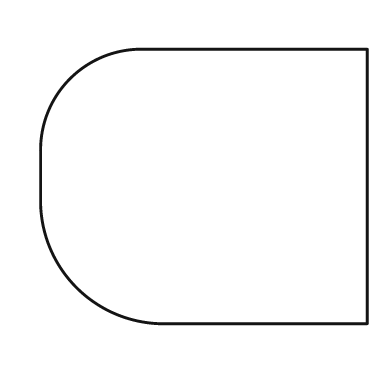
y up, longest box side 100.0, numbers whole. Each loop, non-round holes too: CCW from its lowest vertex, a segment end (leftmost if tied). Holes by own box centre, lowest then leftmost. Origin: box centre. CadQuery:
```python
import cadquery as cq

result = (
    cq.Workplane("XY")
    .moveTo(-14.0, -42.0)
    .lineTo(50.0, -42.0)
    .lineTo(50.0, 42.0)
    .lineTo(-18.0, 42.0)
    .threePointArc((-41.0, 33.0), (-50.0, 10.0))
    .lineTo(-50.0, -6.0)
    .threePointArc((-39.0, -31.0), (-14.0, -42.0))
    .close()
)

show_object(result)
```